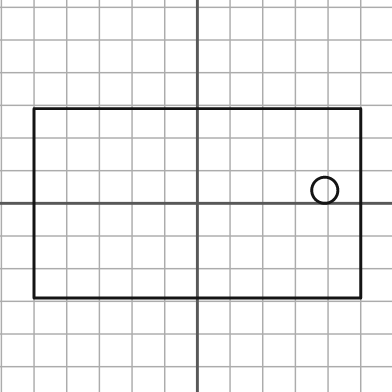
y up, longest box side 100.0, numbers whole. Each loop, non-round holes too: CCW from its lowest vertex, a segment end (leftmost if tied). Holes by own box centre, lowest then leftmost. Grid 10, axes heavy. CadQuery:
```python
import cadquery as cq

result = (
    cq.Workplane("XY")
    .moveTo(-50.0, -29.0)
    .lineTo(50.0, -29.0)
    .lineTo(50.0, 29.0)
    .lineTo(-50.0, 29.0)
    .close()
    .moveTo(39.0, 4.0)
    .circle(4.0)
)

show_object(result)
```